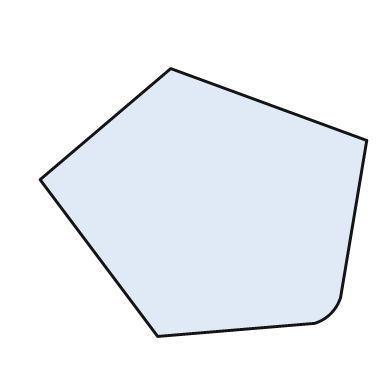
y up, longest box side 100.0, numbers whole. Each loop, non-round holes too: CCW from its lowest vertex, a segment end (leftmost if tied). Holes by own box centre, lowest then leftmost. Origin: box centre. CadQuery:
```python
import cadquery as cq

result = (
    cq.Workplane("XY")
    .moveTo(-14.0, -41.0)
    .lineTo(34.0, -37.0)
    .threePointArc((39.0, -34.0), (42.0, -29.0))
    .lineTo(50.0, 19.0)
    .lineTo(-10.0, 41.0)
    .lineTo(-50.0, 7.0)
    .close()
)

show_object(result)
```